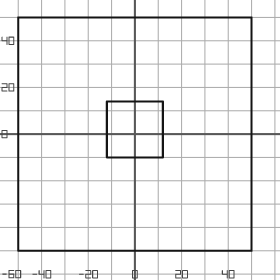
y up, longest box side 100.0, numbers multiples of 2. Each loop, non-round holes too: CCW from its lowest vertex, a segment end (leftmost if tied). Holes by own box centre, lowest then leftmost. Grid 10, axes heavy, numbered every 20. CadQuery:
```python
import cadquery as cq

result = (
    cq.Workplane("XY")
    .moveTo(-50.0, -50.0)
    .lineTo(50.0, -50.0)
    .lineTo(50.0, 50.0)
    .lineTo(-50.0, 50.0)
    .close()
    .moveTo(-12.0, -10.0)
    .lineTo(12.0, -10.0)
    .lineTo(12.0, 14.0)
    .lineTo(-12.0, 14.0)
    .close()
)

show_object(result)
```